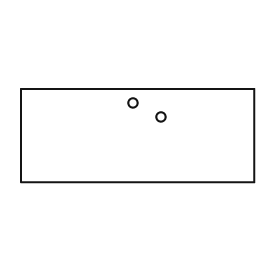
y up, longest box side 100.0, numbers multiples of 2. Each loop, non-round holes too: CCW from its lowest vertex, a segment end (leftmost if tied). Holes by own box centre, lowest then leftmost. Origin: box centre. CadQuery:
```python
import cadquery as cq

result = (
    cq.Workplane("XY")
    .moveTo(-50.0, -20.0)
    .lineTo(50.0, -20.0)
    .lineTo(50.0, 20.0)
    .lineTo(-50.0, 20.0)
    .close()
    .moveTo(10.0, 8.0)
    .circle(2.0)
    .moveTo(-2.0, 14.0)
    .circle(2.0)
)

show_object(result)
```